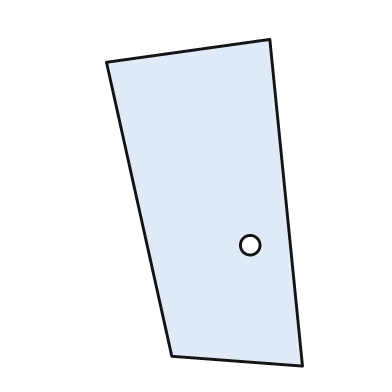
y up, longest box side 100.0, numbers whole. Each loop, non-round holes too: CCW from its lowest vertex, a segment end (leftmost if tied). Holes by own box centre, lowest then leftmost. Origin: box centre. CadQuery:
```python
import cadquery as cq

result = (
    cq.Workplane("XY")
    .moveTo(30.0, -50.0)
    .lineTo(20.0, 50.0)
    .lineTo(-30.0, 43.0)
    .lineTo(-10.0, -47.0)
    .close()
    .moveTo(14.0, -13.0)
    .circle(3.0)
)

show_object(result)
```